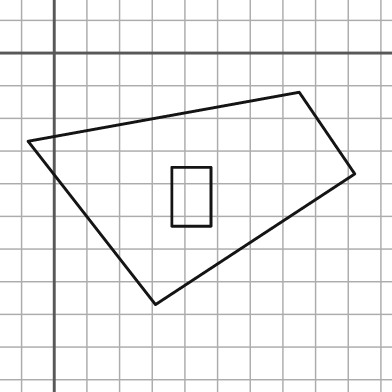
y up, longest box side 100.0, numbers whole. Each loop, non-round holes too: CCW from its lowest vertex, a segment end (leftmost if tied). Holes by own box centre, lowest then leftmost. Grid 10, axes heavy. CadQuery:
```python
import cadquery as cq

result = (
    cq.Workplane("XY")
    .moveTo(31.0, -77.0)
    .lineTo(92.0, -37.0)
    .lineTo(75.0, -12.0)
    .lineTo(-8.0, -27.0)
    .close()
    .moveTo(36.0, -53.0)
    .lineTo(48.0, -53.0)
    .lineTo(48.0, -35.0)
    .lineTo(36.0, -35.0)
    .close()
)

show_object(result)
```